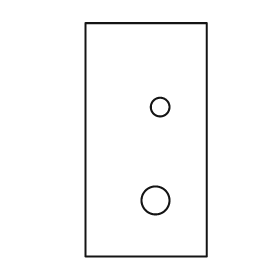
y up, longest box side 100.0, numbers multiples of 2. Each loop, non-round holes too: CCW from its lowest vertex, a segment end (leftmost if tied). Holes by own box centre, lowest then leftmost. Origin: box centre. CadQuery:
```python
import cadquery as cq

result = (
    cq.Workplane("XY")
    .moveTo(-26.0, -50.0)
    .lineTo(26.0, -50.0)
    .lineTo(26.0, 50.0)
    .lineTo(-26.0, 50.0)
    .close()
    .moveTo(4.0, -26.0)
    .circle(6.0)
    .moveTo(6.0, 14.0)
    .circle(4.0)
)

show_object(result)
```